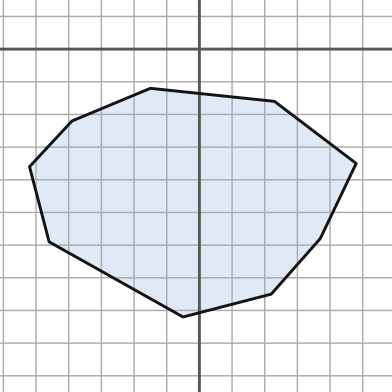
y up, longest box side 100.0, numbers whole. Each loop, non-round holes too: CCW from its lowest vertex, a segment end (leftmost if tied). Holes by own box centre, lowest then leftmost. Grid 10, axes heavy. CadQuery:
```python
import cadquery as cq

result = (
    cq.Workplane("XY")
    .moveTo(-5.0, -82.0)
    .lineTo(22.0, -75.0)
    .lineTo(37.0, -58.0)
    .lineTo(48.0, -35.0)
    .lineTo(23.0, -16.0)
    .lineTo(-15.0, -12.0)
    .lineTo(-39.0, -22.0)
    .lineTo(-52.0, -36.0)
    .lineTo(-46.0, -59.0)
    .close()
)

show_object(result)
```